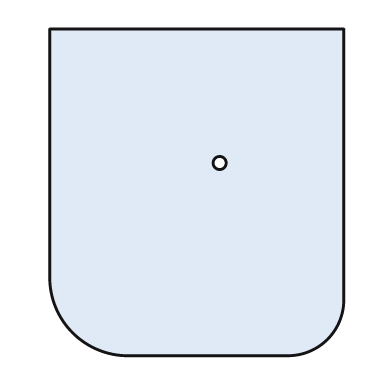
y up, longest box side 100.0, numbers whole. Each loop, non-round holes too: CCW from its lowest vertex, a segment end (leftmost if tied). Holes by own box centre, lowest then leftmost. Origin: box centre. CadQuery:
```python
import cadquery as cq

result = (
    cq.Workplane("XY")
    .moveTo(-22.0, -50.0)
    .lineTo(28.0, -50.0)
    .threePointArc((40.0, -45.0), (45.0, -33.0))
    .lineTo(45.0, 50.0)
    .lineTo(-45.0, 50.0)
    .lineTo(-45.0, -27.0)
    .threePointArc((-38.0, -43.0), (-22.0, -50.0))
    .close()
    .moveTo(7.0, 9.0)
    .circle(2.0)
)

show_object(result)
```